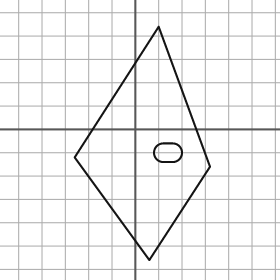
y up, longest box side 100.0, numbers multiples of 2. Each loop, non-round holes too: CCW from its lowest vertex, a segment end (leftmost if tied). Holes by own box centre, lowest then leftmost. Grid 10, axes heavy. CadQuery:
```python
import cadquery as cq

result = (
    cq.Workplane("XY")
    .moveTo(6.0, -56.0)
    .lineTo(32.0, -16.0)
    .lineTo(10.0, 44.0)
    .lineTo(-26.0, -12.0)
    .close()
    .moveTo(12.0, -14.0)
    .lineTo(16.0, -14.0)
    .threePointArc((20.0, -10.0), (16.0, -6.0))
    .lineTo(12.0, -6.0)
    .threePointArc((8.0, -10.0), (12.0, -14.0))
    .close()
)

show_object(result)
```